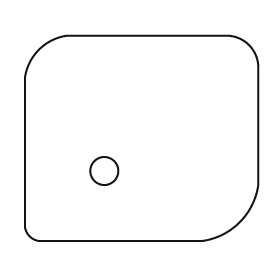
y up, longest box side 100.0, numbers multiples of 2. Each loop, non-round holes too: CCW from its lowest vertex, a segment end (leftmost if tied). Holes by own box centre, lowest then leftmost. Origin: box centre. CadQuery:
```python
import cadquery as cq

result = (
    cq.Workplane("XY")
    .moveTo(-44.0, -44.0)
    .lineTo(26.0, -44.0)
    .threePointArc((42.0, -36.0), (50.0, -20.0))
    .lineTo(50.0, 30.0)
    .threePointArc((46.0, 40.0), (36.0, 44.0))
    .lineTo(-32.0, 44.0)
    .threePointArc((-44.0, 38.0), (-50.0, 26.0))
    .lineTo(-50.0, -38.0)
    .threePointArc((-48.0, -42.0), (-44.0, -44.0))
    .close()
    .moveTo(-16.0, -14.0)
    .circle(6.0)
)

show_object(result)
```